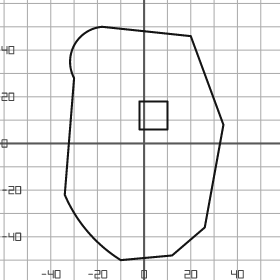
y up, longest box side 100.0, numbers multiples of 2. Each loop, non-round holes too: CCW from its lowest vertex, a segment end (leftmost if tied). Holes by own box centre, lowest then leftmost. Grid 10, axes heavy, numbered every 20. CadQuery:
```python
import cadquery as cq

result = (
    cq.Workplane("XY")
    .moveTo(-10.0, -50.0)
    .lineTo(12.0, -48.0)
    .lineTo(26.0, -36.0)
    .lineTo(34.0, 8.0)
    .lineTo(20.0, 46.0)
    .lineTo(-18.0, 50.0)
    .threePointArc((-30.0, 42.0), (-30.0, 28.0))
    .lineTo(-34.0, -22.0)
    .threePointArc((-24.0, -38.0), (-10.0, -50.0))
    .close()
    .moveTo(-2.0, 6.0)
    .lineTo(10.0, 6.0)
    .lineTo(10.0, 18.0)
    .lineTo(-2.0, 18.0)
    .close()
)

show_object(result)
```